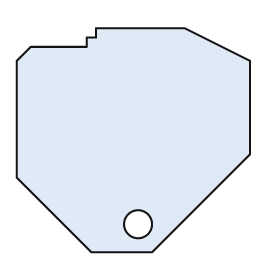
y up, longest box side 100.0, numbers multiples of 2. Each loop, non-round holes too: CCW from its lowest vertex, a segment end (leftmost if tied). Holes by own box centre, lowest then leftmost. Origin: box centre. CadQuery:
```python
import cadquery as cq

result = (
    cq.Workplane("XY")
    .moveTo(-18.0, -48.0)
    .lineTo(8.0, -48.0)
    .lineTo(50.0, -6.0)
    .lineTo(50.0, 34.0)
    .lineTo(22.0, 48.0)
    .lineTo(-16.0, 48.0)
    .lineTo(-16.0, 44.0)
    .lineTo(-20.0, 44.0)
    .lineTo(-20.0, 40.0)
    .lineTo(-44.0, 40.0)
    .lineTo(-50.0, 34.0)
    .lineTo(-50.0, -16.0)
    .close()
    .moveTo(2.0, -36.0)
    .circle(6.0)
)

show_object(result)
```